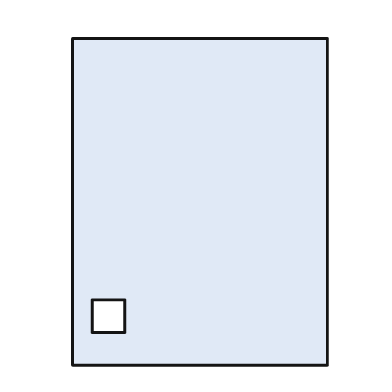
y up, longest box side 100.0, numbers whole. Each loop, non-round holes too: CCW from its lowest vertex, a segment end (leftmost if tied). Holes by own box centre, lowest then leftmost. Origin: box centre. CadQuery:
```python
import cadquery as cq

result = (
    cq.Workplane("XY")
    .moveTo(-39.0, -50.0)
    .lineTo(39.0, -50.0)
    .lineTo(39.0, 50.0)
    .lineTo(-39.0, 50.0)
    .close()
    .moveTo(-33.0, -40.0)
    .lineTo(-23.0, -40.0)
    .lineTo(-23.0, -30.0)
    .lineTo(-33.0, -30.0)
    .close()
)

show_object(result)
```